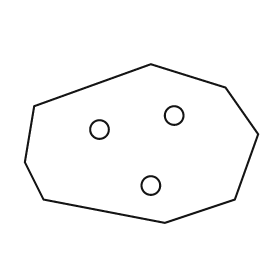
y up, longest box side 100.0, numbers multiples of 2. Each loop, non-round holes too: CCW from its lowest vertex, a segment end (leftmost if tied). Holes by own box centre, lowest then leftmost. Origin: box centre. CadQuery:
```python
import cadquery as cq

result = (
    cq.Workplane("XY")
    .moveTo(10.0, -34.0)
    .lineTo(40.0, -24.0)
    .lineTo(50.0, 4.0)
    .lineTo(36.0, 24.0)
    .lineTo(4.0, 34.0)
    .lineTo(-46.0, 16.0)
    .lineTo(-50.0, -8.0)
    .lineTo(-42.0, -24.0)
    .close()
    .moveTo(4.0, -18.0)
    .circle(4.0)
    .moveTo(-18.0, 6.0)
    .circle(4.0)
    .moveTo(14.0, 12.0)
    .circle(4.0)
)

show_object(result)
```